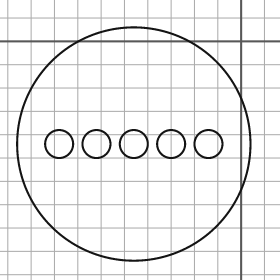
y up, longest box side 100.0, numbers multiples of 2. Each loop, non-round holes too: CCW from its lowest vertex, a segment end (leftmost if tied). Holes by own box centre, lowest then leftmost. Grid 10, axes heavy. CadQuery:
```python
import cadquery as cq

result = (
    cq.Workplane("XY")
    .moveTo(-46.0, -44.0)
    .circle(50.0)
    .moveTo(-78.0, -44.0)
    .circle(6.0)
    .moveTo(-62.0, -44.0)
    .circle(6.0)
    .moveTo(-46.0, -44.0)
    .circle(6.0)
    .moveTo(-30.0, -44.0)
    .circle(6.0)
    .moveTo(-14.0, -44.0)
    .circle(6.0)
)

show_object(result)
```